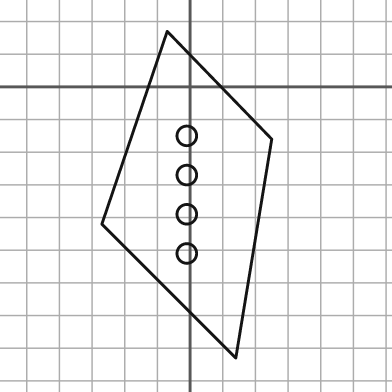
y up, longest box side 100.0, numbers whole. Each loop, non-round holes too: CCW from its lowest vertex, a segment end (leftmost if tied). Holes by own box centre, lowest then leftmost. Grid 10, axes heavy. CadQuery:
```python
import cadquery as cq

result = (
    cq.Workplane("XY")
    .moveTo(14.0, -83.0)
    .lineTo(25.0, -16.0)
    .lineTo(-7.0, 17.0)
    .lineTo(-27.0, -42.0)
    .close()
    .moveTo(-1.0, -51.0)
    .circle(3.0)
    .moveTo(-1.0, -39.0)
    .circle(3.0)
    .moveTo(-1.0, -27.0)
    .circle(3.0)
    .moveTo(-1.0, -15.0)
    .circle(3.0)
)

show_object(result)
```